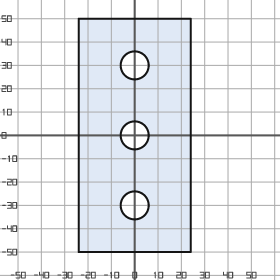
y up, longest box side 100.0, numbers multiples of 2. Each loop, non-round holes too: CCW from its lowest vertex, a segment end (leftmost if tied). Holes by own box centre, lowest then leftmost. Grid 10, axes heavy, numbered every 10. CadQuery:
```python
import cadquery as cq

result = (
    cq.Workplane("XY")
    .moveTo(-24.0, -50.0)
    .lineTo(24.0, -50.0)
    .lineTo(24.0, 50.0)
    .lineTo(-24.0, 50.0)
    .close()
    .moveTo(0.0, -30.0)
    .circle(6.0)
    .moveTo(0.0, 0.0)
    .circle(6.0)
    .moveTo(0.0, 30.0)
    .circle(6.0)
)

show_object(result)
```